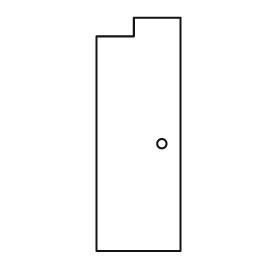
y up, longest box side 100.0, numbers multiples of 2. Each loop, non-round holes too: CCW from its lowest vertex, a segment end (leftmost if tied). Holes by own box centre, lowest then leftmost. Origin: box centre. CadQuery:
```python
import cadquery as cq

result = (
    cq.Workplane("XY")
    .moveTo(-18.0, -50.0)
    .lineTo(18.0, -50.0)
    .lineTo(18.0, 50.0)
    .lineTo(-2.0, 50.0)
    .lineTo(-2.0, 42.0)
    .lineTo(-18.0, 42.0)
    .close()
    .moveTo(10.0, -4.0)
    .circle(2.0)
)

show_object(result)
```